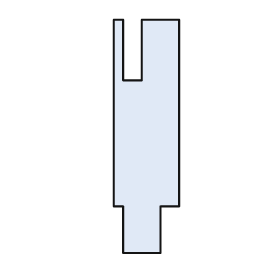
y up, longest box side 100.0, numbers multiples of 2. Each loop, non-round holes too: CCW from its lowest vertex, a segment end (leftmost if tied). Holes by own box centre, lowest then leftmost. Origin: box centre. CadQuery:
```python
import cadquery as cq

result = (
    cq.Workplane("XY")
    .moveTo(-10.0, -50.0)
    .lineTo(6.0, -50.0)
    .lineTo(6.0, -30.0)
    .lineTo(14.0, -30.0)
    .lineTo(14.0, 50.0)
    .lineTo(-2.0, 50.0)
    .lineTo(-2.0, 24.0)
    .lineTo(-10.0, 24.0)
    .lineTo(-10.0, 50.0)
    .lineTo(-14.0, 50.0)
    .lineTo(-14.0, -30.0)
    .lineTo(-10.0, -30.0)
    .close()
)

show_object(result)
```